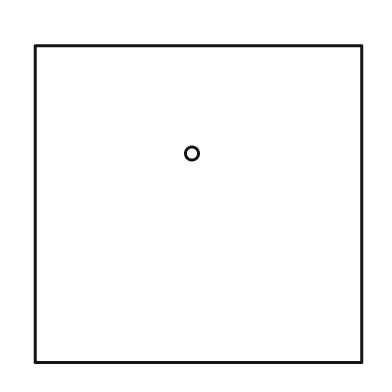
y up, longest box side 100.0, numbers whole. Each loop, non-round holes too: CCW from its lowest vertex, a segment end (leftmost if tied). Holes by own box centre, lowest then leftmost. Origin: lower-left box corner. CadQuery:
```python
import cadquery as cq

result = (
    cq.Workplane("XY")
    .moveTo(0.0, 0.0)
    .lineTo(100.0, 0.0)
    .lineTo(100.0, 97.0)
    .lineTo(0.0, 97.0)
    .close()
    .moveTo(48.0, 64.0)
    .circle(2.0)
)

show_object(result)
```